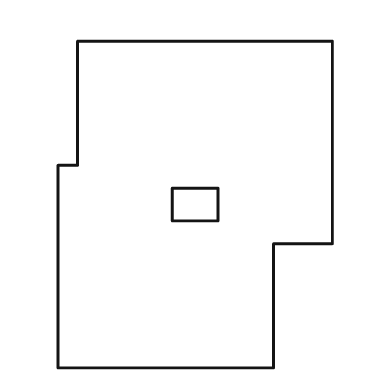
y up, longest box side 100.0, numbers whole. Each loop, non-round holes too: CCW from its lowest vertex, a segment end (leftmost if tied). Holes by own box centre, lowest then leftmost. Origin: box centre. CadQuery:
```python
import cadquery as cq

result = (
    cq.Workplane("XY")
    .moveTo(-42.0, -50.0)
    .lineTo(24.0, -50.0)
    .lineTo(24.0, -12.0)
    .lineTo(42.0, -12.0)
    .lineTo(42.0, 50.0)
    .lineTo(-36.0, 50.0)
    .lineTo(-36.0, 12.0)
    .lineTo(-42.0, 12.0)
    .close()
    .moveTo(-7.0, -5.0)
    .lineTo(7.0, -5.0)
    .lineTo(7.0, 5.0)
    .lineTo(-7.0, 5.0)
    .close()
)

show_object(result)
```